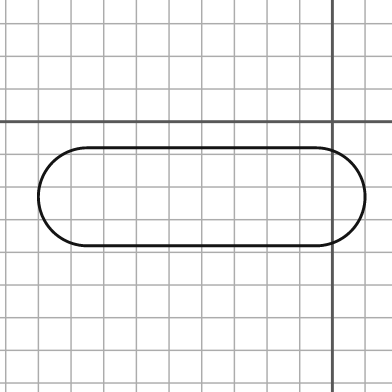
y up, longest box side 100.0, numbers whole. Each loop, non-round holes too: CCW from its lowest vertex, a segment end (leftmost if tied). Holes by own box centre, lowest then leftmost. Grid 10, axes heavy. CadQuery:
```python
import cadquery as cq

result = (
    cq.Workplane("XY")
    .moveTo(-75.0, -38.0)
    .lineTo(-5.0, -38.0)
    .threePointArc((10.0, -23.0), (-5.0, -8.0))
    .lineTo(-75.0, -8.0)
    .threePointArc((-90.0, -23.0), (-75.0, -38.0))
    .close()
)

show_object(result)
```